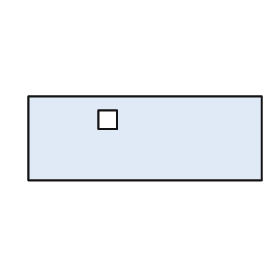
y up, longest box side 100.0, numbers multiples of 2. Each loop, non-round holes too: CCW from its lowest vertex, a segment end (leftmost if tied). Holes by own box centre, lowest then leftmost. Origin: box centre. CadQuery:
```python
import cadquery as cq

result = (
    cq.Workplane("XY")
    .moveTo(-50.0, -18.0)
    .lineTo(50.0, -18.0)
    .lineTo(50.0, 18.0)
    .lineTo(-50.0, 18.0)
    .close()
    .moveTo(-20.0, 4.0)
    .lineTo(-12.0, 4.0)
    .lineTo(-12.0, 12.0)
    .lineTo(-20.0, 12.0)
    .close()
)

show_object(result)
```